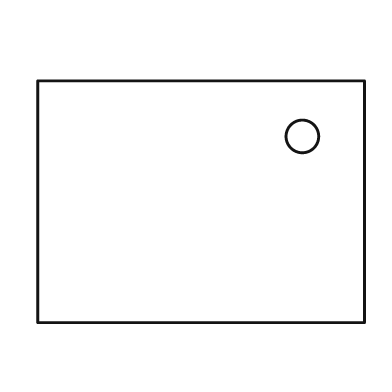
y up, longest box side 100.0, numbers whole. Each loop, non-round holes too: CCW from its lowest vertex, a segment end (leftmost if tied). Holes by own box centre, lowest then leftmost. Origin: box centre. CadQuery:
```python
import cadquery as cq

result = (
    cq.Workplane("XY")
    .moveTo(-50.0, -37.0)
    .lineTo(50.0, -37.0)
    .lineTo(50.0, 37.0)
    .lineTo(-50.0, 37.0)
    .close()
    .moveTo(31.0, 20.0)
    .circle(5.0)
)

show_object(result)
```